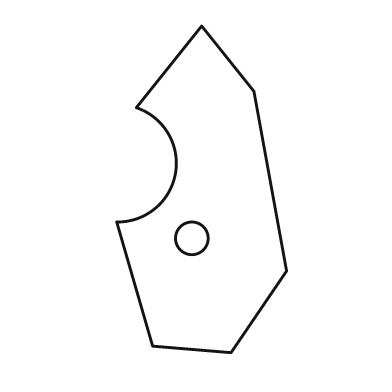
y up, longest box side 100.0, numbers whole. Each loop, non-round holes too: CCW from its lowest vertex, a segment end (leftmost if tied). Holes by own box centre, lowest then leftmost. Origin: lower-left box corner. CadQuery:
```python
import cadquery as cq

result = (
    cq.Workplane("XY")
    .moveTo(35.0, 0.0)
    .lineTo(52.0, 25.0)
    .lineTo(42.0, 80.0)
    .lineTo(26.0, 100.0)
    .lineTo(6.0, 75.0)
    .threePointArc((18.0, 55.0), (0.0, 40.0))
    .lineTo(11.0, 2.0)
    .close()
    .moveTo(23.0, 35.0)
    .circle(5.0)
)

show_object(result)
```